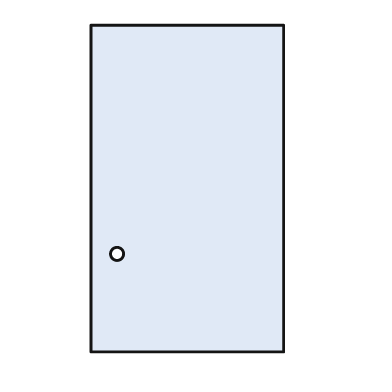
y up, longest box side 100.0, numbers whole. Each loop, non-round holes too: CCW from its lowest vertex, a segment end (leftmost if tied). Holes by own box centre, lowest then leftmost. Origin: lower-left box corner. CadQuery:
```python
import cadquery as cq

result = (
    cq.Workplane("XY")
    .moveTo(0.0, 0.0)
    .lineTo(59.0, 0.0)
    .lineTo(59.0, 100.0)
    .lineTo(0.0, 100.0)
    .close()
    .moveTo(8.0, 30.0)
    .circle(2.0)
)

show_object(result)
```